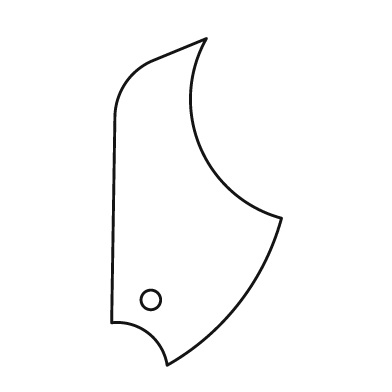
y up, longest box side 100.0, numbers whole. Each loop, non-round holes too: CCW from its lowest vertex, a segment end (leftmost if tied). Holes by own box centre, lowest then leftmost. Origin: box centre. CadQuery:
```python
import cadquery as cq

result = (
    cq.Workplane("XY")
    .moveTo(-9.0, -50.0)
    .threePointArc((13.0, -31.0), (26.0, -5.0))
    .threePointArc((1.0, 17.0), (3.0, 50.0))
    .lineTo(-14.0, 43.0)
    .threePointArc((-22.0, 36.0), (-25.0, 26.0))
    .lineTo(-26.0, -37.0)
    .threePointArc((-15.0, -40.0), (-9.0, -50.0))
    .close()
    .moveTo(-14.0, -30.0)
    .circle(3.0)
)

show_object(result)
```